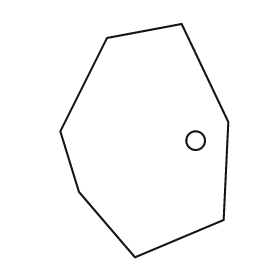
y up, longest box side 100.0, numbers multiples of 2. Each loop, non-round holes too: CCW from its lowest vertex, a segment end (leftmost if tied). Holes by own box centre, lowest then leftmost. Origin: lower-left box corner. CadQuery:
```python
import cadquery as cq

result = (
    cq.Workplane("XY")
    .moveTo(32.0, 0.0)
    .lineTo(70.0, 16.0)
    .lineTo(72.0, 58.0)
    .lineTo(52.0, 100.0)
    .lineTo(20.0, 94.0)
    .lineTo(0.0, 54.0)
    .lineTo(8.0, 28.0)
    .close()
    .moveTo(58.0, 50.0)
    .circle(4.0)
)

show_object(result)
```